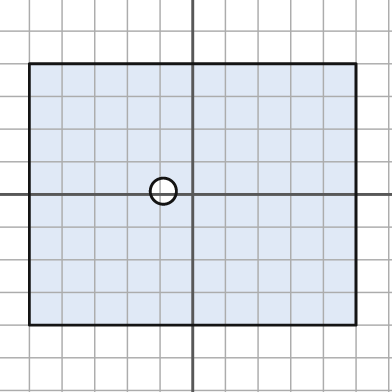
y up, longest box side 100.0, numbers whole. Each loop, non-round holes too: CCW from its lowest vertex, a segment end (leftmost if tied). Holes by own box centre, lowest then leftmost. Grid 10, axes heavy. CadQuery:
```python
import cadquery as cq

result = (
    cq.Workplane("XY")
    .moveTo(-50.0, -40.0)
    .lineTo(50.0, -40.0)
    .lineTo(50.0, 40.0)
    .lineTo(-50.0, 40.0)
    .close()
    .moveTo(-9.0, 1.0)
    .circle(4.0)
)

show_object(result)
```